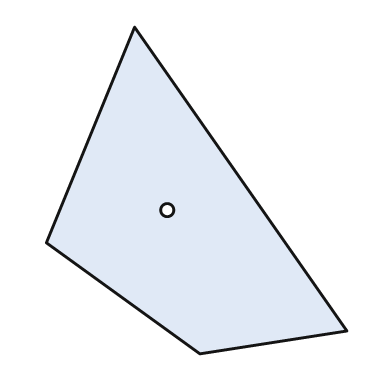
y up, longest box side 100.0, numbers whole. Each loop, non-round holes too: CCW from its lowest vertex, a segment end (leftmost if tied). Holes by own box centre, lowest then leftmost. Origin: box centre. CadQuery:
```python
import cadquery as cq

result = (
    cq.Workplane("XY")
    .moveTo(1.0, -50.0)
    .lineTo(46.0, -43.0)
    .lineTo(-19.0, 50.0)
    .lineTo(-46.0, -16.0)
    .close()
    .moveTo(-9.0, -6.0)
    .circle(2.0)
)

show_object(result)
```